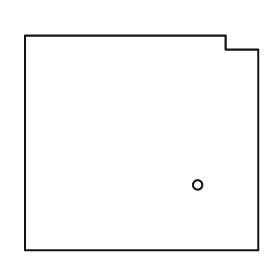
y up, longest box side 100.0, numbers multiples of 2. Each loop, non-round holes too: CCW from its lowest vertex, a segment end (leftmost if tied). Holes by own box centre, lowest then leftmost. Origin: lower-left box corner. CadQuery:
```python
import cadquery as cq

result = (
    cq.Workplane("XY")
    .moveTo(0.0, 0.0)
    .lineTo(100.0, 0.0)
    .lineTo(100.0, 86.0)
    .lineTo(86.0, 86.0)
    .lineTo(86.0, 92.0)
    .lineTo(0.0, 92.0)
    .close()
    .moveTo(74.0, 28.0)
    .circle(2.0)
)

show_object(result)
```